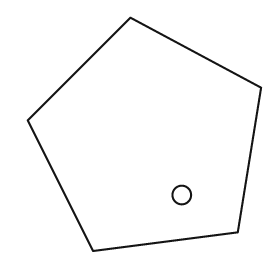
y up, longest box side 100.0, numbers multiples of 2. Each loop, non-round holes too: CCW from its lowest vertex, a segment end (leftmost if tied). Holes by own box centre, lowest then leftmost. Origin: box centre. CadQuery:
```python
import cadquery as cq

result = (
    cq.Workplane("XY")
    .moveTo(-22.0, -50.0)
    .lineTo(40.0, -42.0)
    .lineTo(50.0, 20.0)
    .lineTo(-6.0, 50.0)
    .lineTo(-50.0, 6.0)
    .close()
    .moveTo(16.0, -26.0)
    .circle(4.0)
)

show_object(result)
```